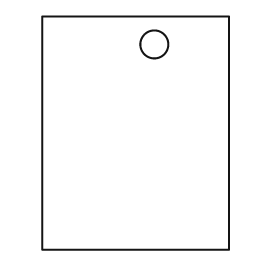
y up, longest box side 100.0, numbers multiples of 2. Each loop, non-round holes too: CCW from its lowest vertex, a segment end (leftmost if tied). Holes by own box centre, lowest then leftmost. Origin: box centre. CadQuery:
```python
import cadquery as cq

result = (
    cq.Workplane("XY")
    .moveTo(-40.0, -50.0)
    .lineTo(40.0, -50.0)
    .lineTo(40.0, 50.0)
    .lineTo(-40.0, 50.0)
    .close()
    .moveTo(8.0, 38.0)
    .circle(6.0)
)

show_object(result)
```